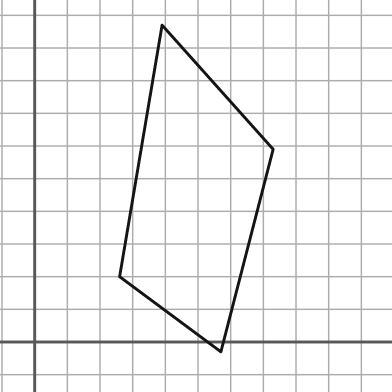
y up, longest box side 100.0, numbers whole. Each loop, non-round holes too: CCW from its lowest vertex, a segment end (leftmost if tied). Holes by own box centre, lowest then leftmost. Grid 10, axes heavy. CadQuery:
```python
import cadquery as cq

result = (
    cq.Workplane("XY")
    .moveTo(57.0, -3.0)
    .lineTo(73.0, 59.0)
    .lineTo(39.0, 97.0)
    .lineTo(26.0, 20.0)
    .close()
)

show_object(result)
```